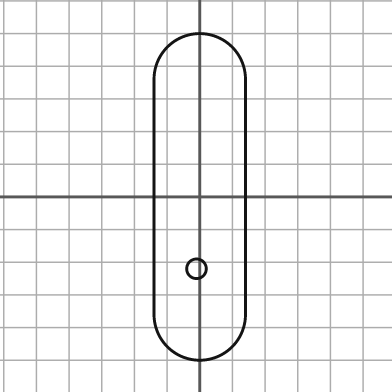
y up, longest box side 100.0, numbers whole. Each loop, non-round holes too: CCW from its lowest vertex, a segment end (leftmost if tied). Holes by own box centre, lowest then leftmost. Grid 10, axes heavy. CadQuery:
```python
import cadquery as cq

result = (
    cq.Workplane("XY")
    .moveTo(-14.0, -36.0)
    .threePointArc((0.0, -50.0), (14.0, -36.0))
    .lineTo(14.0, 36.0)
    .threePointArc((0.0, 50.0), (-14.0, 36.0))
    .close()
    .moveTo(-1.0, -22.0)
    .circle(3.0)
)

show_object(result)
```